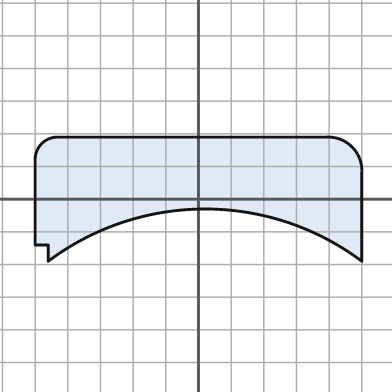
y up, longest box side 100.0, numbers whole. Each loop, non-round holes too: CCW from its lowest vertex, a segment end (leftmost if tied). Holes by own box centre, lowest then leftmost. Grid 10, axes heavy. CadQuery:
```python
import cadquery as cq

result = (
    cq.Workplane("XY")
    .moveTo(-46.0, -19.0)
    .threePointArc((2.0, -3.0), (50.0, -19.0))
    .lineTo(50.0, 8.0)
    .threePointArc((47.0, 16.0), (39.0, 19.0))
    .lineTo(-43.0, 19.0)
    .threePointArc((-48.0, 17.0), (-50.0, 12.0))
    .lineTo(-50.0, -14.0)
    .lineTo(-46.0, -14.0)
    .close()
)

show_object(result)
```